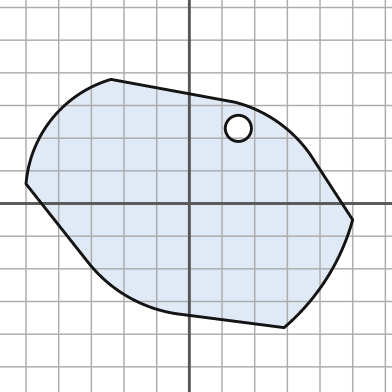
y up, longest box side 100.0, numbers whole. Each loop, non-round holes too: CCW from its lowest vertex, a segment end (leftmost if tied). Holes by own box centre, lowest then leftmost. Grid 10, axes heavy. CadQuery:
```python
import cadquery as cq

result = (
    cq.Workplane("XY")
    .moveTo(29.0, -38.0)
    .threePointArc((42.0, -23.0), (50.0, -5.0))
    .lineTo(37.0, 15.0)
    .threePointArc((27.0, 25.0), (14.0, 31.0))
    .lineTo(-24.0, 38.0)
    .threePointArc((-42.0, 26.0), (-50.0, 6.0))
    .lineTo(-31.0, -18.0)
    .threePointArc((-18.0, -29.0), (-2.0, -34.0))
    .close()
    .moveTo(15.0, 23.0)
    .circle(4.0)
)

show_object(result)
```